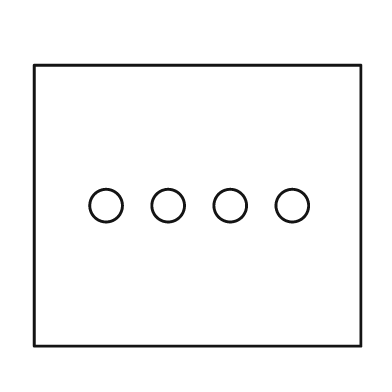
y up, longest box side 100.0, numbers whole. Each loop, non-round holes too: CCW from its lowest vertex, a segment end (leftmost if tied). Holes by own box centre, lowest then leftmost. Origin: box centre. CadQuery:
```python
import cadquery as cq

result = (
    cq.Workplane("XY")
    .moveTo(-50.0, -43.0)
    .lineTo(50.0, -43.0)
    .lineTo(50.0, 43.0)
    .lineTo(-50.0, 43.0)
    .close()
    .moveTo(-28.0, 0.0)
    .circle(5.0)
    .moveTo(-9.0, 0.0)
    .circle(5.0)
    .moveTo(10.0, 0.0)
    .circle(5.0)
    .moveTo(29.0, 0.0)
    .circle(5.0)
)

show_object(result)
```